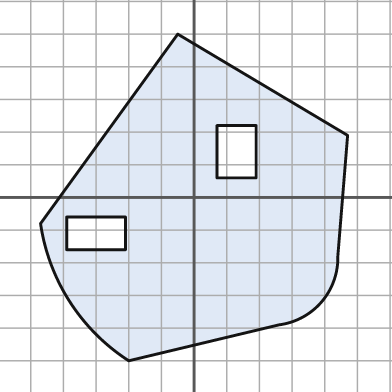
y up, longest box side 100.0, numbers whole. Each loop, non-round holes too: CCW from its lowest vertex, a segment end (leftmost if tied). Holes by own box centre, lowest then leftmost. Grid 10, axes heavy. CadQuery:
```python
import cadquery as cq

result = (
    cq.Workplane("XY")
    .moveTo(-20.0, -50.0)
    .lineTo(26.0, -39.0)
    .threePointArc((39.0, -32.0), (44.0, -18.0))
    .lineTo(47.0, 19.0)
    .lineTo(-5.0, 50.0)
    .lineTo(-47.0, -8.0)
    .threePointArc((-38.0, -32.0), (-20.0, -50.0))
    .close()
    .moveTo(-39.0, -16.0)
    .lineTo(-21.0, -16.0)
    .lineTo(-21.0, -6.0)
    .lineTo(-39.0, -6.0)
    .close()
    .moveTo(7.0, 6.0)
    .lineTo(19.0, 6.0)
    .lineTo(19.0, 22.0)
    .lineTo(7.0, 22.0)
    .close()
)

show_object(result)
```